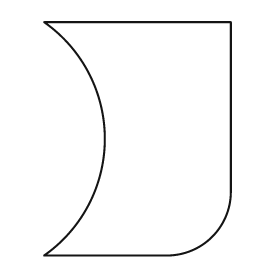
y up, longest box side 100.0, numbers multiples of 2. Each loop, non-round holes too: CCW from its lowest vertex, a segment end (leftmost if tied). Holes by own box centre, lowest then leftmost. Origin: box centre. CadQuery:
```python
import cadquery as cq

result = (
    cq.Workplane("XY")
    .moveTo(-40.0, -50.0)
    .lineTo(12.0, -50.0)
    .threePointArc((32.0, -42.0), (40.0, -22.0))
    .lineTo(40.0, 50.0)
    .lineTo(-40.0, 50.0)
    .threePointArc((-14.0, 0.0), (-40.0, -50.0))
    .close()
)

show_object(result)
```